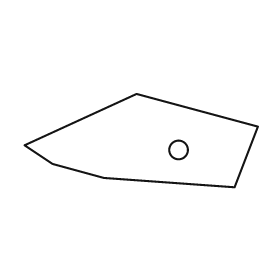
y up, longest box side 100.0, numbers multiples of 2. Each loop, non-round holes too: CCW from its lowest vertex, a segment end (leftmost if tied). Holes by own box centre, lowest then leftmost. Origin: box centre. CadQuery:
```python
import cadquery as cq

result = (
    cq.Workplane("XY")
    .moveTo(40.0, -20.0)
    .lineTo(50.0, 6.0)
    .lineTo(-2.0, 20.0)
    .lineTo(-50.0, -2.0)
    .lineTo(-38.0, -10.0)
    .lineTo(-16.0, -16.0)
    .close()
    .moveTo(16.0, -4.0)
    .circle(4.0)
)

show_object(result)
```